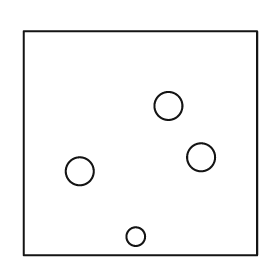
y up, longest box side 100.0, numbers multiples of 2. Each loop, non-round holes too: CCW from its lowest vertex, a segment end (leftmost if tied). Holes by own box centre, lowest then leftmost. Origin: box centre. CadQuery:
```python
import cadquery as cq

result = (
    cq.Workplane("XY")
    .moveTo(-50.0, -48.0)
    .lineTo(50.0, -48.0)
    .lineTo(50.0, 48.0)
    .lineTo(-50.0, 48.0)
    .close()
    .moveTo(-2.0, -40.0)
    .circle(4.0)
    .moveTo(-26.0, -12.0)
    .circle(6.0)
    .moveTo(26.0, -6.0)
    .circle(6.0)
    .moveTo(12.0, 16.0)
    .circle(6.0)
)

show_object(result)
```